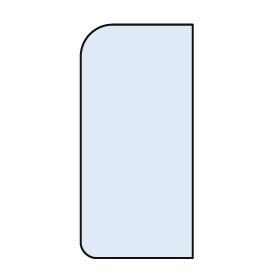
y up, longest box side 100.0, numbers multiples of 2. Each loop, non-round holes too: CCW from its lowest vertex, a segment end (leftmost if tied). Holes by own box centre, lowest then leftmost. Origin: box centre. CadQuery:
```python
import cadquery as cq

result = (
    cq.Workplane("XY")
    .moveTo(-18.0, -50.0)
    .lineTo(24.0, -50.0)
    .lineTo(24.0, 50.0)
    .lineTo(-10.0, 50.0)
    .threePointArc((-20.0, 46.0), (-24.0, 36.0))
    .lineTo(-24.0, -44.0)
    .threePointArc((-22.0, -48.0), (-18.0, -50.0))
    .close()
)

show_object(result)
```